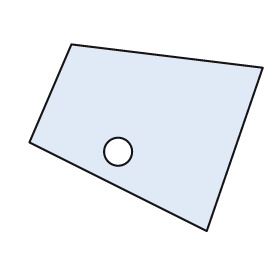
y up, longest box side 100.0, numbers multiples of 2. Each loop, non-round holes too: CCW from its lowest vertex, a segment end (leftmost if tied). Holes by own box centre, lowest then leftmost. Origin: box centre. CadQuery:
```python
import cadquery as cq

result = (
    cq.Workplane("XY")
    .moveTo(26.0, -40.0)
    .lineTo(50.0, 30.0)
    .lineTo(-32.0, 40.0)
    .lineTo(-50.0, -2.0)
    .close()
    .moveTo(-12.0, -6.0)
    .circle(6.0)
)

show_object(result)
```